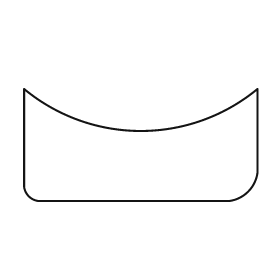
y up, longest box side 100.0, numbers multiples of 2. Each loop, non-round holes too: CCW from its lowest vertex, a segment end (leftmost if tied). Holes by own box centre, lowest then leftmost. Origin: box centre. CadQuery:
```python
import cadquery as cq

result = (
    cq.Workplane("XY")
    .moveTo(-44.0, -24.0)
    .lineTo(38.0, -24.0)
    .threePointArc((46.0, -20.0), (50.0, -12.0))
    .lineTo(50.0, 24.0)
    .threePointArc((0.0, 6.0), (-50.0, 24.0))
    .lineTo(-50.0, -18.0)
    .threePointArc((-48.0, -22.0), (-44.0, -24.0))
    .close()
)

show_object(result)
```